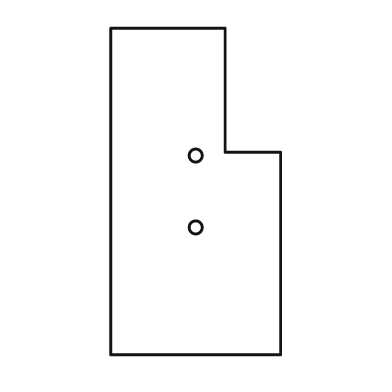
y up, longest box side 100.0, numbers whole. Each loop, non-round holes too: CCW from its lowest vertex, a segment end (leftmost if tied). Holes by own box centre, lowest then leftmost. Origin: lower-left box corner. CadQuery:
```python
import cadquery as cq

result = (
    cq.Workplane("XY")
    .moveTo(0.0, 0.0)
    .lineTo(52.0, 0.0)
    .lineTo(52.0, 62.0)
    .lineTo(35.0, 62.0)
    .lineTo(35.0, 100.0)
    .lineTo(0.0, 100.0)
    .close()
    .moveTo(26.0, 39.0)
    .circle(2.0)
    .moveTo(26.0, 61.0)
    .circle(2.0)
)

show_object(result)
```